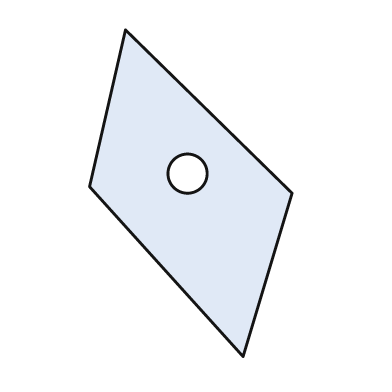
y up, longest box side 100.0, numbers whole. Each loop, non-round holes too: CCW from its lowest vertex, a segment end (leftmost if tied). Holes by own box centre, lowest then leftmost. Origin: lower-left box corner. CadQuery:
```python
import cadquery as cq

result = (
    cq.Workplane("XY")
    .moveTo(47.0, 0.0)
    .lineTo(62.0, 50.0)
    .lineTo(11.0, 100.0)
    .lineTo(0.0, 52.0)
    .close()
    .moveTo(30.0, 56.0)
    .circle(6.0)
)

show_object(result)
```